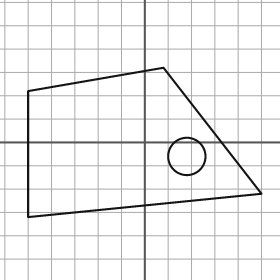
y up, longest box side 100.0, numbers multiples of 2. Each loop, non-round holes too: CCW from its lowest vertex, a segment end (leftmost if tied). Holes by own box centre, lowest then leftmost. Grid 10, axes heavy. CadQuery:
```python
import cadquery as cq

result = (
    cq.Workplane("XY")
    .moveTo(-50.0, -32.0)
    .lineTo(50.0, -22.0)
    .lineTo(8.0, 32.0)
    .lineTo(-50.0, 22.0)
    .close()
    .moveTo(18.0, -6.0)
    .circle(8.0)
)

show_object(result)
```